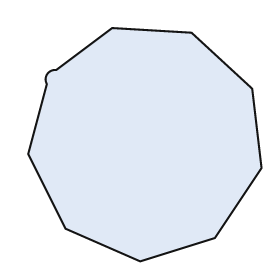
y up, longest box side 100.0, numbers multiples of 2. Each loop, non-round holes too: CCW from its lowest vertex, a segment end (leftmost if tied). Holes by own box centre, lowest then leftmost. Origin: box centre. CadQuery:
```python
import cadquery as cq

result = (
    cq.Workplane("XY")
    .moveTo(-2.0, -50.0)
    .lineTo(30.0, -40.0)
    .lineTo(50.0, -10.0)
    .lineTo(46.0, 24.0)
    .lineTo(20.0, 48.0)
    .lineTo(-14.0, 50.0)
    .lineTo(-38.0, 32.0)
    .threePointArc((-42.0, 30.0), (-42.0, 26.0))
    .lineTo(-50.0, -4.0)
    .lineTo(-34.0, -36.0)
    .close()
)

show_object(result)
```